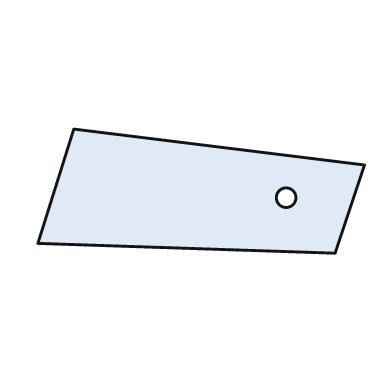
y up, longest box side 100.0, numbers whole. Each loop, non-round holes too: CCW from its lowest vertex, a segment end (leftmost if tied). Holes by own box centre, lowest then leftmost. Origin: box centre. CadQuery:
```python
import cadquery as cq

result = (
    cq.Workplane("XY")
    .moveTo(41.0, -19.0)
    .lineTo(50.0, 8.0)
    .lineTo(-39.0, 19.0)
    .lineTo(-50.0, -16.0)
    .close()
    .moveTo(26.0, -2.0)
    .circle(3.0)
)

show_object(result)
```